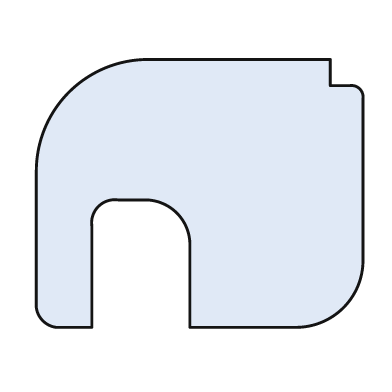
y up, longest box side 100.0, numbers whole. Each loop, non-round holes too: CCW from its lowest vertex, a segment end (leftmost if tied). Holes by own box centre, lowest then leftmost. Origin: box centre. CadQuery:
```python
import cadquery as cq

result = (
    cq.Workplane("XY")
    .moveTo(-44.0, -41.0)
    .lineTo(-33.0, -41.0)
    .lineTo(-33.0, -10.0)
    .threePointArc((-31.0, -4.0), (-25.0, -2.0))
    .lineTo(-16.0, -2.0)
    .threePointArc((-7.0, -6.0), (-3.0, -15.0))
    .lineTo(-3.0, -41.0)
    .lineTo(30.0, -41.0)
    .threePointArc((44.0, -35.0), (50.0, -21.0))
    .lineTo(50.0, 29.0)
    .threePointArc((49.0, 32.0), (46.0, 33.0))
    .lineTo(40.0, 33.0)
    .lineTo(40.0, 41.0)
    .lineTo(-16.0, 41.0)
    .threePointArc((-40.0, 31.0), (-50.0, 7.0))
    .lineTo(-50.0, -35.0)
    .threePointArc((-48.0, -39.0), (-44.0, -41.0))
    .close()
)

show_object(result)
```